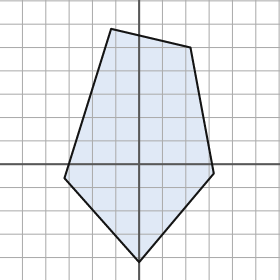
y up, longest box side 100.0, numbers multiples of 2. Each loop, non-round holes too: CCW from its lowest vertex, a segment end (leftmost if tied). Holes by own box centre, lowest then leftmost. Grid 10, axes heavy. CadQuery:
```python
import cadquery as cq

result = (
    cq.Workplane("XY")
    .moveTo(0.0, -42.0)
    .lineTo(32.0, -4.0)
    .lineTo(22.0, 50.0)
    .lineTo(-12.0, 58.0)
    .lineTo(-32.0, -6.0)
    .close()
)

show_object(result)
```